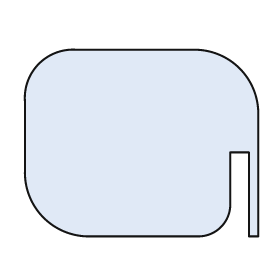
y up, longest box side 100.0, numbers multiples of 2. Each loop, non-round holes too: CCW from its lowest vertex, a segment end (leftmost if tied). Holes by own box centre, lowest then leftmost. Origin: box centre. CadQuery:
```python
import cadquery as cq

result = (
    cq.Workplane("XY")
    .moveTo(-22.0, -40.0)
    .lineTo(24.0, -40.0)
    .threePointArc((34.0, -36.0), (38.0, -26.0))
    .lineTo(38.0, -4.0)
    .lineTo(46.0, -4.0)
    .lineTo(46.0, -40.0)
    .lineTo(50.0, -40.0)
    .lineTo(50.0, 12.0)
    .threePointArc((42.0, 32.0), (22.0, 40.0))
    .lineTo(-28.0, 40.0)
    .threePointArc((-44.0, 34.0), (-50.0, 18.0))
    .lineTo(-50.0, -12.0)
    .threePointArc((-42.0, -32.0), (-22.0, -40.0))
    .close()
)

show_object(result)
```